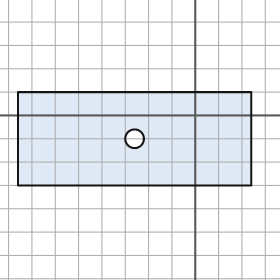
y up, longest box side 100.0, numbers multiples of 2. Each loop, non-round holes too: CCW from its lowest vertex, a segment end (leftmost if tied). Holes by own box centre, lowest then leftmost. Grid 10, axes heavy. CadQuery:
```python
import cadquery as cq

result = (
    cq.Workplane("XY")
    .moveTo(-76.0, -30.0)
    .lineTo(24.0, -30.0)
    .lineTo(24.0, 10.0)
    .lineTo(-76.0, 10.0)
    .close()
    .moveTo(-26.0, -10.0)
    .circle(4.0)
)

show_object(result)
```